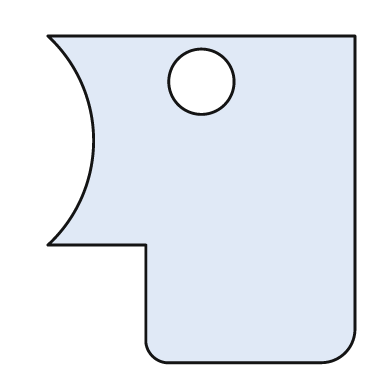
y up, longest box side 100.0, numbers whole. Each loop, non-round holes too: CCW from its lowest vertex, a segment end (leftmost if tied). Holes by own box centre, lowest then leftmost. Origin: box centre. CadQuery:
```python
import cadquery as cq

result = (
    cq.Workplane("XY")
    .moveTo(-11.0, -50.0)
    .lineTo(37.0, -50.0)
    .threePointArc((44.0, -47.0), (47.0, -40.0))
    .lineTo(47.0, 50.0)
    .lineTo(-47.0, 50.0)
    .threePointArc((-33.0, 18.0), (-47.0, -14.0))
    .lineTo(-17.0, -14.0)
    .lineTo(-17.0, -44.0)
    .threePointArc((-15.0, -48.0), (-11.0, -50.0))
    .close()
    .moveTo(0.0, 36.0)
    .circle(10.0)
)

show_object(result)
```